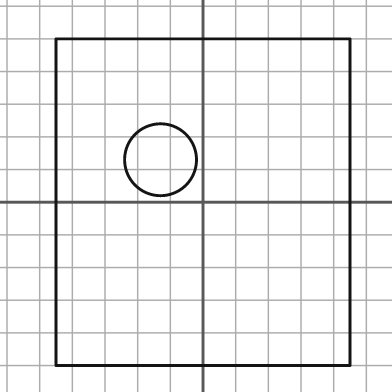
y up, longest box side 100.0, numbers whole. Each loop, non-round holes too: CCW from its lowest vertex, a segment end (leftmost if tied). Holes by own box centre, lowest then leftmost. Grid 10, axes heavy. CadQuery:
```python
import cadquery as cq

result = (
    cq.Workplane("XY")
    .moveTo(-45.0, -50.0)
    .lineTo(45.0, -50.0)
    .lineTo(45.0, 50.0)
    .lineTo(-45.0, 50.0)
    .close()
    .moveTo(-13.0, 13.0)
    .circle(11.0)
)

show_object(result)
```